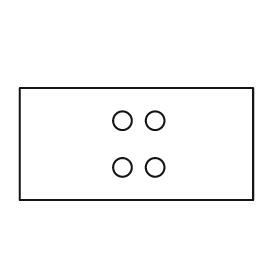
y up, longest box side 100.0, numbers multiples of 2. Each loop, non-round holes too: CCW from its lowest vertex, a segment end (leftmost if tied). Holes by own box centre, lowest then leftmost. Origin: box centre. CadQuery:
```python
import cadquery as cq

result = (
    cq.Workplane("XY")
    .moveTo(-50.0, -24.0)
    .lineTo(50.0, -24.0)
    .lineTo(50.0, 24.0)
    .lineTo(-50.0, 24.0)
    .close()
    .moveTo(-6.0, -10.0)
    .circle(4.0)
    .moveTo(8.0, -10.0)
    .circle(4.0)
    .moveTo(-6.0, 10.0)
    .circle(4.0)
    .moveTo(8.0, 10.0)
    .circle(4.0)
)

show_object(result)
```